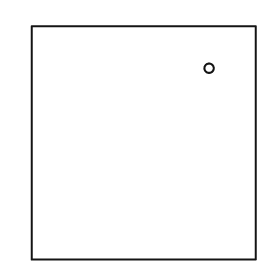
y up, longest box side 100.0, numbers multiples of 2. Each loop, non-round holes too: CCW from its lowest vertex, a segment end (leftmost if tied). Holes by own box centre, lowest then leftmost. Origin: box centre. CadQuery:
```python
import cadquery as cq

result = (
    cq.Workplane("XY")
    .moveTo(-48.0, -50.0)
    .lineTo(48.0, -50.0)
    .lineTo(48.0, 50.0)
    .lineTo(-48.0, 50.0)
    .close()
    .moveTo(28.0, 32.0)
    .circle(2.0)
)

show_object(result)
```